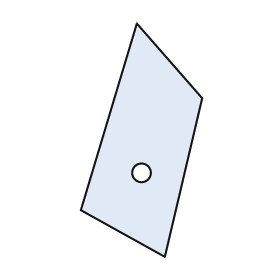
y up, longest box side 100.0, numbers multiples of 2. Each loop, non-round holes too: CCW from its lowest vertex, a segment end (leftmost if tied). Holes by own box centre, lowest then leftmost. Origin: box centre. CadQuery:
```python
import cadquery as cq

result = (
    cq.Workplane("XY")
    .moveTo(10.0, -50.0)
    .lineTo(26.0, 18.0)
    .lineTo(-2.0, 50.0)
    .lineTo(-26.0, -30.0)
    .close()
    .moveTo(0.0, -14.0)
    .circle(4.0)
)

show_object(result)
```